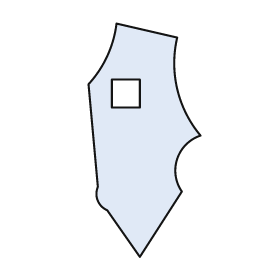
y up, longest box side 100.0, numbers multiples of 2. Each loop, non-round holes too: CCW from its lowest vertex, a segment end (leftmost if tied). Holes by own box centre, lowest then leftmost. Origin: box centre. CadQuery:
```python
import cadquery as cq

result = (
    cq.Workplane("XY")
    .moveTo(-2.0, -50.0)
    .lineTo(16.0, -22.0)
    .threePointArc((14.0, -8.0), (24.0, 2.0))
    .threePointArc((14.0, 22.0), (14.0, 44.0))
    .lineTo(-12.0, 50.0)
    .threePointArc((-16.0, 36.0), (-24.0, 24.0))
    .lineTo(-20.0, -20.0)
    .threePointArc((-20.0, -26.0), (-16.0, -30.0))
    .close()
    .moveTo(-14.0, 14.0)
    .lineTo(-2.0, 14.0)
    .lineTo(-2.0, 26.0)
    .lineTo(-14.0, 26.0)
    .close()
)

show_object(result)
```